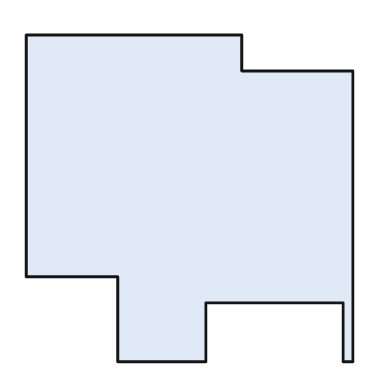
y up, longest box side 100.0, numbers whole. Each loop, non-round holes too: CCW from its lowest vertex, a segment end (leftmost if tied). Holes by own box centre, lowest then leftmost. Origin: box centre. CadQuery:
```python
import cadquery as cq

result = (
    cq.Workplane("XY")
    .moveTo(-22.0, -50.0)
    .lineTo(5.0, -50.0)
    .lineTo(5.0, -32.0)
    .lineTo(47.0, -32.0)
    .lineTo(47.0, -50.0)
    .lineTo(50.0, -50.0)
    .lineTo(50.0, 39.0)
    .lineTo(16.0, 39.0)
    .lineTo(16.0, 50.0)
    .lineTo(-50.0, 50.0)
    .lineTo(-50.0, -24.0)
    .lineTo(-22.0, -24.0)
    .close()
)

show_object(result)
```